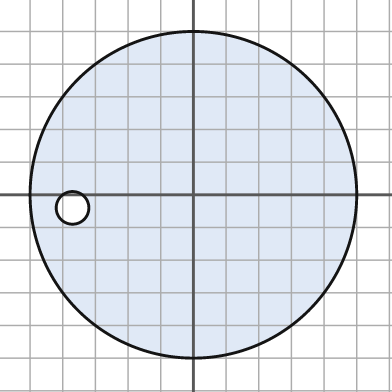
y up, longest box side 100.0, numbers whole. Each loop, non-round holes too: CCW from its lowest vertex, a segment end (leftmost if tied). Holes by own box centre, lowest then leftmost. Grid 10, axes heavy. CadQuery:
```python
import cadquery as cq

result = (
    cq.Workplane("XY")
    .moveTo(0.0, 0.0)
    .circle(50.0)
    .moveTo(-37.0, -4.0)
    .circle(5.0)
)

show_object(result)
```